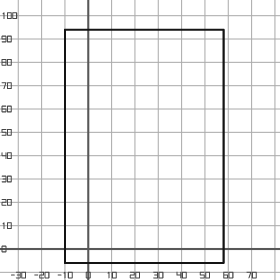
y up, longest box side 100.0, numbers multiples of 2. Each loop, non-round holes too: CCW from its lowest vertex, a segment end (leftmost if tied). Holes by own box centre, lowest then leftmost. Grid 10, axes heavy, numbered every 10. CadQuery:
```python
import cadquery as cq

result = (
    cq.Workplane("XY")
    .moveTo(-10.0, -6.0)
    .lineTo(58.0, -6.0)
    .lineTo(58.0, 94.0)
    .lineTo(-10.0, 94.0)
    .close()
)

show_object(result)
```